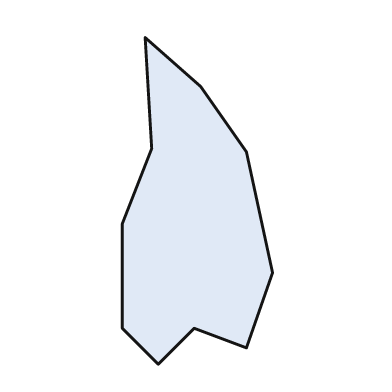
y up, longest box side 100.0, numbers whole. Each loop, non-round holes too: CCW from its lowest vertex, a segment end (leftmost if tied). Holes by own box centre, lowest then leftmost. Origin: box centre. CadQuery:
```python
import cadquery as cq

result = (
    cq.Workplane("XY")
    .moveTo(-12.0, -50.0)
    .lineTo(-1.0, -39.0)
    .lineTo(15.0, -45.0)
    .lineTo(23.0, -22.0)
    .lineTo(15.0, 15.0)
    .lineTo(1.0, 35.0)
    .lineTo(-16.0, 50.0)
    .lineTo(-14.0, 16.0)
    .lineTo(-23.0, -7.0)
    .lineTo(-23.0, -39.0)
    .close()
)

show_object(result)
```